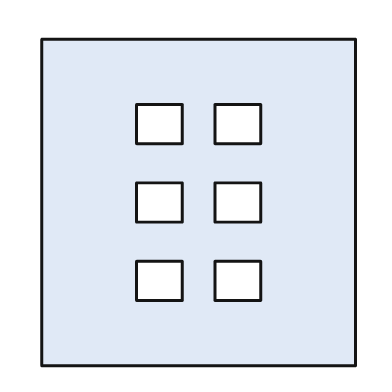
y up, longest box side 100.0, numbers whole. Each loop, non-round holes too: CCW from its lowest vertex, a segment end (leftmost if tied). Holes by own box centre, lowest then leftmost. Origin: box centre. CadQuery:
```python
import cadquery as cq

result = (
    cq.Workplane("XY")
    .moveTo(-48.0, -50.0)
    .lineTo(48.0, -50.0)
    .lineTo(48.0, 50.0)
    .lineTo(-48.0, 50.0)
    .close()
    .moveTo(-19.0, -30.0)
    .lineTo(-5.0, -30.0)
    .lineTo(-5.0, -18.0)
    .lineTo(-19.0, -18.0)
    .close()
    .moveTo(5.0, -30.0)
    .lineTo(19.0, -30.0)
    .lineTo(19.0, -18.0)
    .lineTo(5.0, -18.0)
    .close()
    .moveTo(-19.0, -6.0)
    .lineTo(-5.0, -6.0)
    .lineTo(-5.0, 6.0)
    .lineTo(-19.0, 6.0)
    .close()
    .moveTo(5.0, -6.0)
    .lineTo(19.0, -6.0)
    .lineTo(19.0, 6.0)
    .lineTo(5.0, 6.0)
    .close()
    .moveTo(-19.0, 18.0)
    .lineTo(-5.0, 18.0)
    .lineTo(-5.0, 30.0)
    .lineTo(-19.0, 30.0)
    .close()
    .moveTo(5.0, 18.0)
    .lineTo(19.0, 18.0)
    .lineTo(19.0, 30.0)
    .lineTo(5.0, 30.0)
    .close()
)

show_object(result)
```